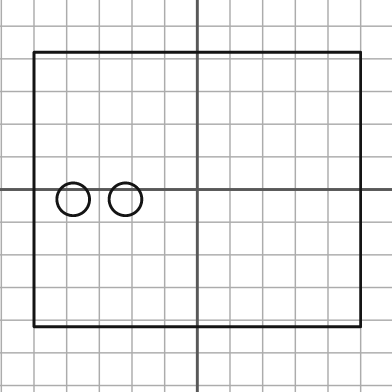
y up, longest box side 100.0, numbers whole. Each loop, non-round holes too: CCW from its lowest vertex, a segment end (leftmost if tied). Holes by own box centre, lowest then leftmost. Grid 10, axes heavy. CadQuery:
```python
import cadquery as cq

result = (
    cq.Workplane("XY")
    .moveTo(-50.0, -42.0)
    .lineTo(50.0, -42.0)
    .lineTo(50.0, 42.0)
    .lineTo(-50.0, 42.0)
    .close()
    .moveTo(-38.0, -3.0)
    .circle(5.0)
    .moveTo(-22.0, -3.0)
    .circle(5.0)
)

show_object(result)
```